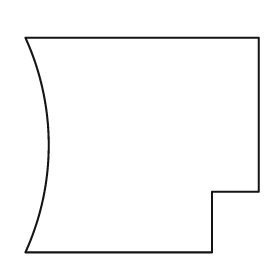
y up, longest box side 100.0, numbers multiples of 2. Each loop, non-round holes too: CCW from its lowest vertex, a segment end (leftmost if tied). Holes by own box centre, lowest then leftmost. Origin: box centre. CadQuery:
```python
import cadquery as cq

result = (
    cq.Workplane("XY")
    .moveTo(-50.0, -46.0)
    .lineTo(30.0, -46.0)
    .lineTo(30.0, -20.0)
    .lineTo(50.0, -20.0)
    .lineTo(50.0, 46.0)
    .lineTo(-50.0, 46.0)
    .threePointArc((-40.0, 0.0), (-50.0, -46.0))
    .close()
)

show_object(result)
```